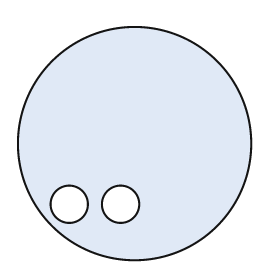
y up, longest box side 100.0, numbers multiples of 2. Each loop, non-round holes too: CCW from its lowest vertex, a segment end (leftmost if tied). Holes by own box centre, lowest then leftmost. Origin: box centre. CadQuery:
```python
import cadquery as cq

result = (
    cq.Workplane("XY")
    .moveTo(0.0, 0.0)
    .circle(50.0)
    .moveTo(-28.0, -26.0)
    .circle(8.0)
    .moveTo(-6.0, -26.0)
    .circle(8.0)
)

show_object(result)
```